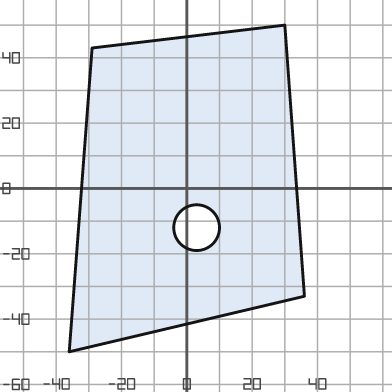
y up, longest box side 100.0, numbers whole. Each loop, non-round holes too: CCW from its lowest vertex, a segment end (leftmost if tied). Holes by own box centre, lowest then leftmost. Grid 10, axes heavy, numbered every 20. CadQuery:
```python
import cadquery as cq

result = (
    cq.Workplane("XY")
    .moveTo(-36.0, -50.0)
    .lineTo(36.0, -33.0)
    .lineTo(30.0, 50.0)
    .lineTo(-29.0, 43.0)
    .close()
    .moveTo(3.0, -12.0)
    .circle(7.0)
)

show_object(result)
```